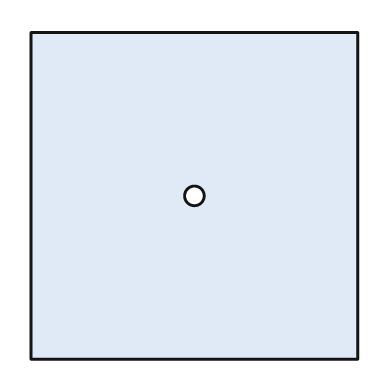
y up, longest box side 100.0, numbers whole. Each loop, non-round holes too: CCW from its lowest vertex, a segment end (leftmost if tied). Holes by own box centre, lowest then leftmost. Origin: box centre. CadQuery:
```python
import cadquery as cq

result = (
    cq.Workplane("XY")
    .moveTo(-50.0, -50.0)
    .lineTo(50.0, -50.0)
    .lineTo(50.0, 50.0)
    .lineTo(-50.0, 50.0)
    .close()
    .moveTo(0.0, 0.0)
    .circle(3.0)
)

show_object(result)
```